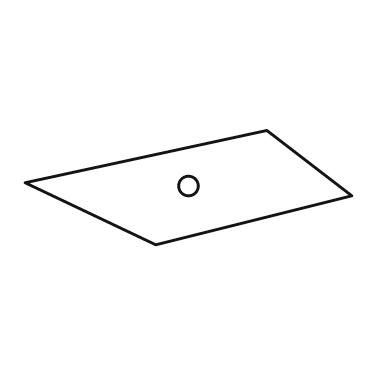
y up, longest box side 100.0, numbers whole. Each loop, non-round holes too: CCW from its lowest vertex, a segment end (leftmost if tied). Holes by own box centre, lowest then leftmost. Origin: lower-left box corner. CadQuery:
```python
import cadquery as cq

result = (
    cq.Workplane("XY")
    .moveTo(40.0, 0.0)
    .lineTo(100.0, 15.0)
    .lineTo(74.0, 35.0)
    .lineTo(0.0, 19.0)
    .close()
    .moveTo(50.0, 18.0)
    .circle(3.0)
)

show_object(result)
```